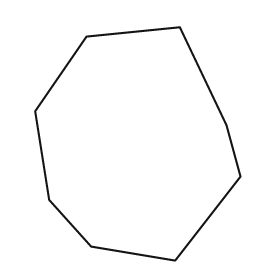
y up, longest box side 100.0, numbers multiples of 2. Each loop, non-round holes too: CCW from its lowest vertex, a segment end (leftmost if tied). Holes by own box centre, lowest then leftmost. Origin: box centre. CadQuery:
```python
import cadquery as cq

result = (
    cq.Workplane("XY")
    .moveTo(16.0, -50.0)
    .lineTo(44.0, -14.0)
    .lineTo(38.0, 8.0)
    .lineTo(18.0, 50.0)
    .lineTo(-22.0, 46.0)
    .lineTo(-44.0, 14.0)
    .lineTo(-38.0, -24.0)
    .lineTo(-20.0, -44.0)
    .close()
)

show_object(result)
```